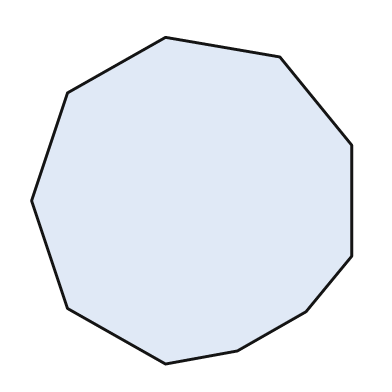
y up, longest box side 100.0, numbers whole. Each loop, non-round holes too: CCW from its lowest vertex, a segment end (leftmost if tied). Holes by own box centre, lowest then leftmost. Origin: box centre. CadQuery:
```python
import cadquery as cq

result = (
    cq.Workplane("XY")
    .moveTo(-8.0, -50.0)
    .lineTo(14.0, -46.0)
    .lineTo(35.0, -34.0)
    .lineTo(49.0, -17.0)
    .lineTo(49.0, 17.0)
    .lineTo(27.0, 44.0)
    .lineTo(-8.0, 50.0)
    .lineTo(-38.0, 33.0)
    .lineTo(-49.0, 0.0)
    .lineTo(-38.0, -33.0)
    .close()
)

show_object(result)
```